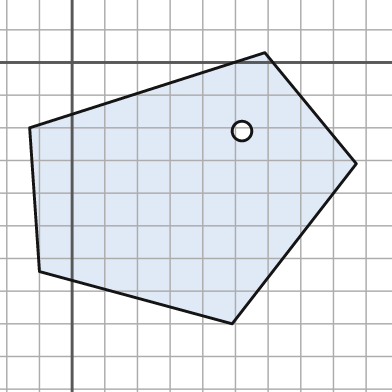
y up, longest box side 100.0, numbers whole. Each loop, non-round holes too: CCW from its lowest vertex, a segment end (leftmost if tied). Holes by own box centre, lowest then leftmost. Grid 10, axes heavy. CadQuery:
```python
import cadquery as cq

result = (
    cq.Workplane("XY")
    .moveTo(49.0, -80.0)
    .lineTo(87.0, -31.0)
    .lineTo(59.0, 3.0)
    .lineTo(-13.0, -20.0)
    .lineTo(-10.0, -64.0)
    .close()
    .moveTo(52.0, -21.0)
    .circle(3.0)
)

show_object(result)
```